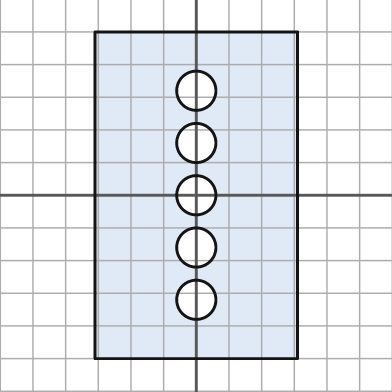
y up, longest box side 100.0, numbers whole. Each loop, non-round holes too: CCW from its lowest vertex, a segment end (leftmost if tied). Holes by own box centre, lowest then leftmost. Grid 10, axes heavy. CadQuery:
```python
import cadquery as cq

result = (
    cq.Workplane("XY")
    .moveTo(-31.0, -50.0)
    .lineTo(31.0, -50.0)
    .lineTo(31.0, 50.0)
    .lineTo(-31.0, 50.0)
    .close()
    .moveTo(0.0, -32.0)
    .circle(6.0)
    .moveTo(0.0, -16.0)
    .circle(6.0)
    .moveTo(0.0, 0.0)
    .circle(6.0)
    .moveTo(0.0, 16.0)
    .circle(6.0)
    .moveTo(0.0, 32.0)
    .circle(6.0)
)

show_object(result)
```